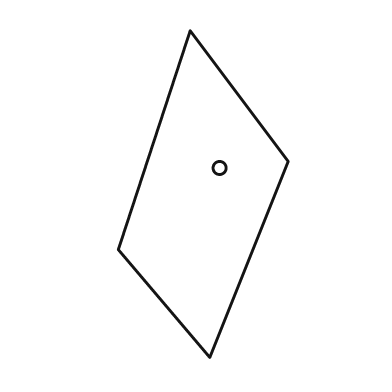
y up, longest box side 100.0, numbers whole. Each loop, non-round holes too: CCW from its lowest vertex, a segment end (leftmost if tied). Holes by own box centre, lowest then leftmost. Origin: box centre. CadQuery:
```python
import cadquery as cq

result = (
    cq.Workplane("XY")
    .moveTo(2.0, -50.0)
    .lineTo(26.0, 10.0)
    .lineTo(-4.0, 50.0)
    .lineTo(-26.0, -17.0)
    .close()
    .moveTo(5.0, 8.0)
    .circle(2.0)
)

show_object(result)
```